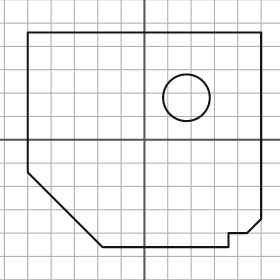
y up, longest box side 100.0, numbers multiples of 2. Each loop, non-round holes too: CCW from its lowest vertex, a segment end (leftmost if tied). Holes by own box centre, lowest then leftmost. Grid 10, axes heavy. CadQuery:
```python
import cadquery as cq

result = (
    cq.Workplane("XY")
    .moveTo(-18.0, -46.0)
    .lineTo(36.0, -46.0)
    .lineTo(36.0, -40.0)
    .lineTo(44.0, -40.0)
    .lineTo(50.0, -34.0)
    .lineTo(50.0, 46.0)
    .lineTo(-50.0, 46.0)
    .lineTo(-50.0, -14.0)
    .close()
    .moveTo(18.0, 18.0)
    .circle(10.0)
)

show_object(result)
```